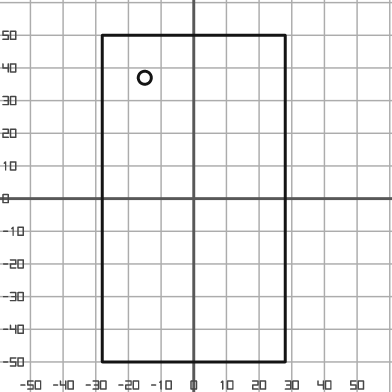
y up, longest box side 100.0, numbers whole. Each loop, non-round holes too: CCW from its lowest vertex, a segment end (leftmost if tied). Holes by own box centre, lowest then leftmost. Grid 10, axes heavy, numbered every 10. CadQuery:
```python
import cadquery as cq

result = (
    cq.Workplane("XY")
    .moveTo(-28.0, -50.0)
    .lineTo(28.0, -50.0)
    .lineTo(28.0, 50.0)
    .lineTo(-28.0, 50.0)
    .close()
    .moveTo(-15.0, 37.0)
    .circle(2.0)
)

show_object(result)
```